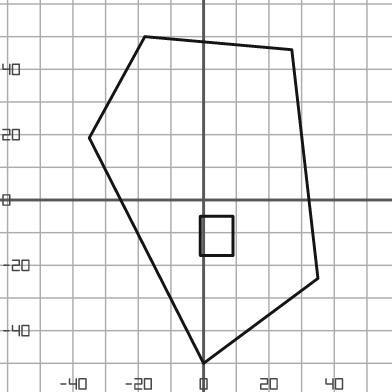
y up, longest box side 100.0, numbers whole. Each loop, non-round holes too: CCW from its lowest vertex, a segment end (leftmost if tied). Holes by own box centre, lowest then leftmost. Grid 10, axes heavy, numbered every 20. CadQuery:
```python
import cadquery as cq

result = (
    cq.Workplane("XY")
    .moveTo(0.0, -50.0)
    .lineTo(35.0, -24.0)
    .lineTo(27.0, 46.0)
    .lineTo(-18.0, 50.0)
    .lineTo(-35.0, 19.0)
    .close()
    .moveTo(-1.0, -17.0)
    .lineTo(9.0, -17.0)
    .lineTo(9.0, -5.0)
    .lineTo(-1.0, -5.0)
    .close()
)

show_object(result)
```